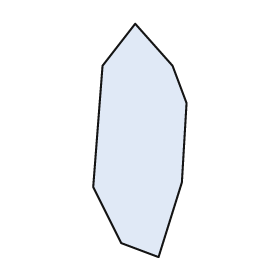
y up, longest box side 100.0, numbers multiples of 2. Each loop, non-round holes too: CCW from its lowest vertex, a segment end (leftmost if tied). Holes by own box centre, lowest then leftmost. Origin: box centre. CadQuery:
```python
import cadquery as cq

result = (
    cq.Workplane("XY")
    .moveTo(8.0, -50.0)
    .lineTo(18.0, -18.0)
    .lineTo(20.0, 16.0)
    .lineTo(14.0, 32.0)
    .lineTo(-2.0, 50.0)
    .lineTo(-16.0, 32.0)
    .lineTo(-20.0, -20.0)
    .lineTo(-8.0, -44.0)
    .close()
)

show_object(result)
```